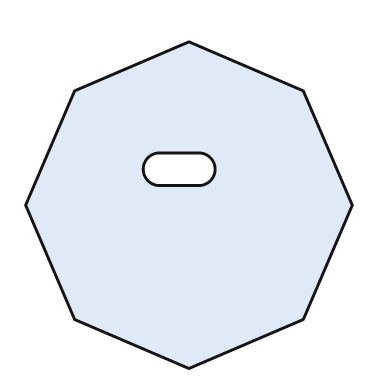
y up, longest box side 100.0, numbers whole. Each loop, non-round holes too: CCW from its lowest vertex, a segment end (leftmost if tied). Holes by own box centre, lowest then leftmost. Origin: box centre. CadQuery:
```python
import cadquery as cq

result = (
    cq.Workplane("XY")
    .moveTo(0.0, -50.0)
    .lineTo(35.0, -35.0)
    .lineTo(50.0, 0.0)
    .lineTo(35.0, 35.0)
    .lineTo(0.0, 50.0)
    .lineTo(-35.0, 35.0)
    .lineTo(-50.0, 0.0)
    .lineTo(-35.0, -35.0)
    .close()
    .moveTo(-9.0, 6.0)
    .lineTo(3.0, 6.0)
    .threePointArc((8.0, 11.0), (3.0, 16.0))
    .lineTo(-9.0, 16.0)
    .threePointArc((-14.0, 11.0), (-9.0, 6.0))
    .close()
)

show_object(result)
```